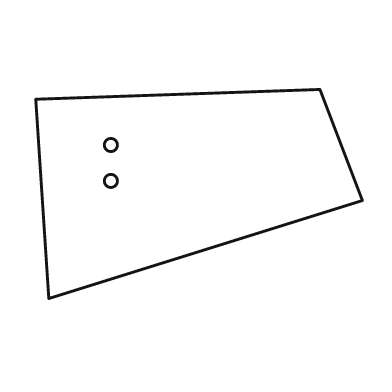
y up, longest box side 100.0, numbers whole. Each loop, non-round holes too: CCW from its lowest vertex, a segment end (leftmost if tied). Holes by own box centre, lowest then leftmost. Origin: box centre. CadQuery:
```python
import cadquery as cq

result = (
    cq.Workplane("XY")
    .moveTo(-46.0, -32.0)
    .lineTo(50.0, -2.0)
    .lineTo(37.0, 32.0)
    .lineTo(-50.0, 29.0)
    .close()
    .moveTo(-27.0, 4.0)
    .circle(2.0)
    .moveTo(-27.0, 15.0)
    .circle(2.0)
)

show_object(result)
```